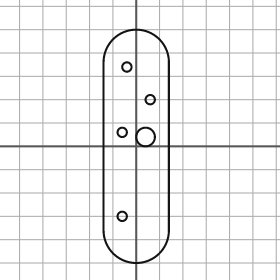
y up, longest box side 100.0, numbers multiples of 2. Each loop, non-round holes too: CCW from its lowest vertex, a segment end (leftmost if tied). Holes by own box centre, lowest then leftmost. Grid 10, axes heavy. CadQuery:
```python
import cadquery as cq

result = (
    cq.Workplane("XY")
    .moveTo(-14.0, -36.0)
    .threePointArc((0.0, -50.0), (14.0, -36.0))
    .lineTo(14.0, 36.0)
    .threePointArc((0.0, 50.0), (-14.0, 36.0))
    .close()
    .moveTo(-6.0, -30.0)
    .circle(2.0)
    .moveTo(4.0, 4.0)
    .circle(4.0)
    .moveTo(-6.0, 6.0)
    .circle(2.0)
    .moveTo(6.0, 20.0)
    .circle(2.0)
    .moveTo(-4.0, 34.0)
    .circle(2.0)
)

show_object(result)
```